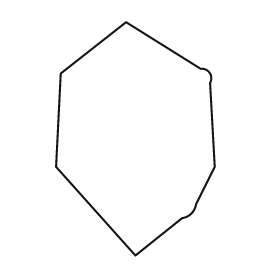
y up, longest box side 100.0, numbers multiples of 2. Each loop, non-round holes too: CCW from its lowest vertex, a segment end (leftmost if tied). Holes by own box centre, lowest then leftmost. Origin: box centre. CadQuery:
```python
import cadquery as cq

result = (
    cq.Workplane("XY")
    .moveTo(0.0, -50.0)
    .lineTo(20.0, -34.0)
    .threePointArc((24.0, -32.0), (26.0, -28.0))
    .lineTo(34.0, -12.0)
    .lineTo(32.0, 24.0)
    .threePointArc((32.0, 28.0), (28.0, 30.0))
    .lineTo(-4.0, 50.0)
    .lineTo(-32.0, 28.0)
    .lineTo(-34.0, -12.0)
    .close()
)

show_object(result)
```